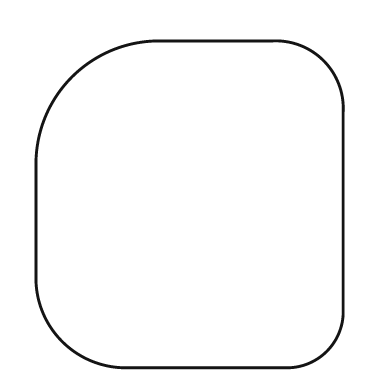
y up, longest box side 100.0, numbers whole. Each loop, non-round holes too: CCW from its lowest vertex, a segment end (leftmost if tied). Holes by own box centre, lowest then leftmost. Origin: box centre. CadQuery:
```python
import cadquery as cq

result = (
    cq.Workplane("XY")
    .moveTo(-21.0, -50.0)
    .lineTo(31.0, -50.0)
    .threePointArc((42.0, -45.0), (47.0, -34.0))
    .lineTo(47.0, 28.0)
    .threePointArc((41.0, 44.0), (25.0, 50.0))
    .lineTo(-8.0, 50.0)
    .threePointArc((-36.0, 39.0), (-47.0, 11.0))
    .lineTo(-47.0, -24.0)
    .threePointArc((-39.0, -42.0), (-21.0, -50.0))
    .close()
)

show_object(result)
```